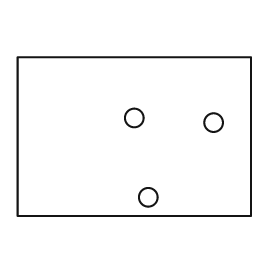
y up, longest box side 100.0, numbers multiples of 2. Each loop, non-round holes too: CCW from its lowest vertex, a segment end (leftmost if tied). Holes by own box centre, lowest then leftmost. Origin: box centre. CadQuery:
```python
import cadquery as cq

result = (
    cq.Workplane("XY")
    .moveTo(-50.0, -34.0)
    .lineTo(50.0, -34.0)
    .lineTo(50.0, 34.0)
    .lineTo(-50.0, 34.0)
    .close()
    .moveTo(6.0, -26.0)
    .circle(4.0)
    .moveTo(34.0, 6.0)
    .circle(4.0)
    .moveTo(0.0, 8.0)
    .circle(4.0)
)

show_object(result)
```